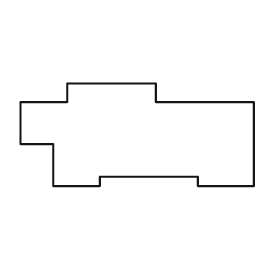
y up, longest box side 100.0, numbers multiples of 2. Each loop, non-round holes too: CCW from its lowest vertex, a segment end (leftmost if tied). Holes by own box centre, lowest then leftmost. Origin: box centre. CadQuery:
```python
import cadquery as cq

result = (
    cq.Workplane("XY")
    .moveTo(-36.0, -22.0)
    .lineTo(-16.0, -22.0)
    .lineTo(-16.0, -18.0)
    .lineTo(26.0, -18.0)
    .lineTo(26.0, -22.0)
    .lineTo(50.0, -22.0)
    .lineTo(50.0, 14.0)
    .lineTo(8.0, 14.0)
    .lineTo(8.0, 22.0)
    .lineTo(-30.0, 22.0)
    .lineTo(-30.0, 14.0)
    .lineTo(-50.0, 14.0)
    .lineTo(-50.0, -4.0)
    .lineTo(-36.0, -4.0)
    .close()
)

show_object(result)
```